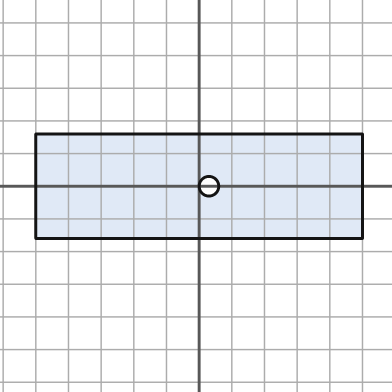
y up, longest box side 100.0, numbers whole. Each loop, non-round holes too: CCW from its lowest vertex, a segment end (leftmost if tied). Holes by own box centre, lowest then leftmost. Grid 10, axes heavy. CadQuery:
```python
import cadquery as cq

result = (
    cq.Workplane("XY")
    .moveTo(-50.0, -16.0)
    .lineTo(50.0, -16.0)
    .lineTo(50.0, 16.0)
    .lineTo(-50.0, 16.0)
    .close()
    .moveTo(3.0, 0.0)
    .circle(3.0)
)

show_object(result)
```